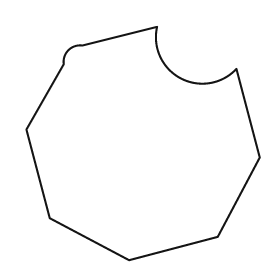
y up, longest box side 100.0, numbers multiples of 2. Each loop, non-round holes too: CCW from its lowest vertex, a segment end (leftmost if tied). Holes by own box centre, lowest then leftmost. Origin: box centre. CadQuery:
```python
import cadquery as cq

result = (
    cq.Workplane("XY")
    .moveTo(-6.0, -50.0)
    .lineTo(32.0, -40.0)
    .lineTo(50.0, -6.0)
    .lineTo(40.0, 32.0)
    .threePointArc((16.0, 28.0), (6.0, 50.0))
    .lineTo(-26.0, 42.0)
    .threePointArc((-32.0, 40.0), (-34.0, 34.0))
    .lineTo(-50.0, 6.0)
    .lineTo(-40.0, -32.0)
    .close()
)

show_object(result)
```